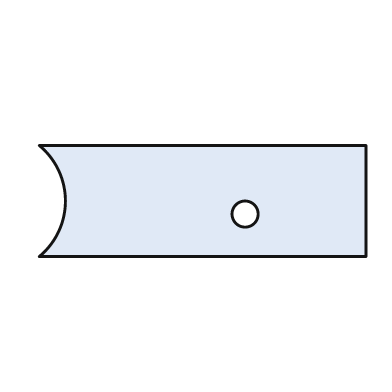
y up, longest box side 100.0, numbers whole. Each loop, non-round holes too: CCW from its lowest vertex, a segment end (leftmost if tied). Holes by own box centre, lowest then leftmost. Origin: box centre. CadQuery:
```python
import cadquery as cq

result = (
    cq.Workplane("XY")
    .moveTo(-50.0, -17.0)
    .lineTo(50.0, -17.0)
    .lineTo(50.0, 17.0)
    .lineTo(-50.0, 17.0)
    .threePointArc((-42.0, 0.0), (-50.0, -17.0))
    .close()
    .moveTo(13.0, -4.0)
    .circle(4.0)
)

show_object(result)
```